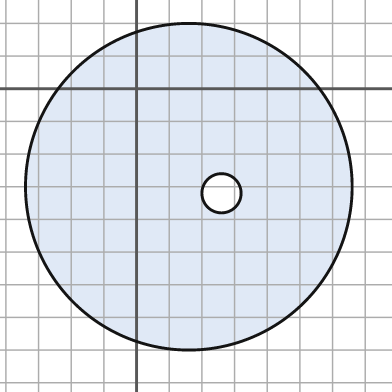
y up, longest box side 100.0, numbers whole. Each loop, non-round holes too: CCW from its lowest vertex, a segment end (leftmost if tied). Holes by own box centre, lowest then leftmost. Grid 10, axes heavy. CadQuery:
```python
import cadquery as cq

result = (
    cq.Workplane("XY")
    .moveTo(16.0, -30.0)
    .circle(50.0)
    .moveTo(26.0, -32.0)
    .circle(6.0)
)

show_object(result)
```